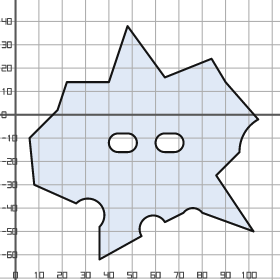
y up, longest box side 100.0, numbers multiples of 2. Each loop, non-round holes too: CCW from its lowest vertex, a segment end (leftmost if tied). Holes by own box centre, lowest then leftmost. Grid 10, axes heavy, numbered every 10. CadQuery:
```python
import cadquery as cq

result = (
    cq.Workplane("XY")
    .moveTo(36.0, -62.0)
    .lineTo(54.0, -52.0)
    .threePointArc((56.0, -44.0), (64.0, -46.0))
    .lineTo(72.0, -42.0)
    .threePointArc((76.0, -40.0), (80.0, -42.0))
    .lineTo(102.0, -50.0)
    .lineTo(86.0, -26.0)
    .lineTo(96.0, -16.0)
    .threePointArc((98.0, -8.0), (104.0, -2.0))
    .lineTo(90.0, 14.0)
    .lineTo(84.0, 24.0)
    .lineTo(64.0, 16.0)
    .lineTo(48.0, 38.0)
    .lineTo(40.0, 14.0)
    .lineTo(22.0, 14.0)
    .lineTo(18.0, 2.0)
    .lineTo(6.0, -10.0)
    .lineTo(8.0, -30.0)
    .lineTo(26.0, -38.0)
    .threePointArc((36.0, -38.0), (36.0, -48.0))
    .close()
    .moveTo(44.0, -16.0)
    .lineTo(48.0, -16.0)
    .threePointArc((52.0, -12.0), (48.0, -8.0))
    .lineTo(44.0, -8.0)
    .threePointArc((40.0, -12.0), (44.0, -16.0))
    .close()
    .moveTo(64.0, -16.0)
    .lineTo(68.0, -16.0)
    .threePointArc((72.0, -12.0), (68.0, -8.0))
    .lineTo(64.0, -8.0)
    .threePointArc((60.0, -12.0), (64.0, -16.0))
    .close()
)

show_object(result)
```